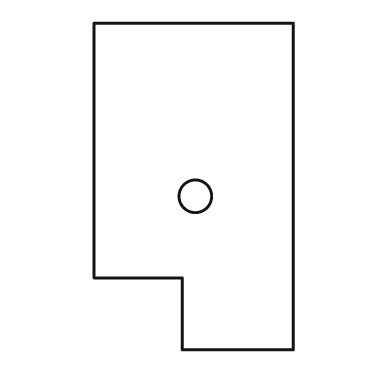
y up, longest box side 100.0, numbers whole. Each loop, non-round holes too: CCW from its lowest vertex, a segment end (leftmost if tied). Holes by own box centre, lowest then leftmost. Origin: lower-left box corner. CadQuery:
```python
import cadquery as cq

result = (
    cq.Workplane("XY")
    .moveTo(27.0, 0.0)
    .lineTo(61.0, 0.0)
    .lineTo(61.0, 100.0)
    .lineTo(0.0, 100.0)
    .lineTo(0.0, 22.0)
    .lineTo(27.0, 22.0)
    .close()
    .moveTo(31.0, 47.0)
    .circle(5.0)
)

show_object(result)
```